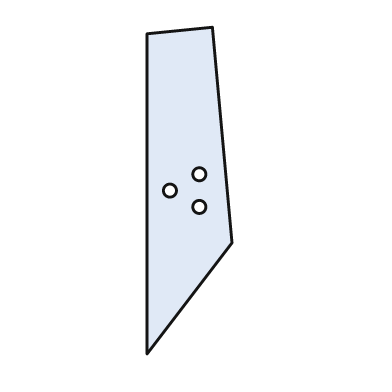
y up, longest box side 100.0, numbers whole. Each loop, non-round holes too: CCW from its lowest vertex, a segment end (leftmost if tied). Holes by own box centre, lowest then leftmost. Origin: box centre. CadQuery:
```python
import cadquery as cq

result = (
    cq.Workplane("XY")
    .moveTo(-13.0, -50.0)
    .lineTo(13.0, -16.0)
    .lineTo(7.0, 50.0)
    .lineTo(-13.0, 48.0)
    .close()
    .moveTo(3.0, -5.0)
    .circle(2.0)
    .moveTo(-6.0, 0.0)
    .circle(2.0)
    .moveTo(3.0, 5.0)
    .circle(2.0)
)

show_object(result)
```